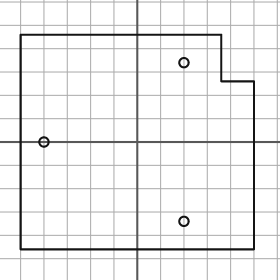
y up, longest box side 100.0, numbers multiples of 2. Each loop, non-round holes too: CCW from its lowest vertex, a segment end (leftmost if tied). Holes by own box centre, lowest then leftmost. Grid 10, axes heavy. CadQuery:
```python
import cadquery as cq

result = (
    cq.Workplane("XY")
    .moveTo(-50.0, -46.0)
    .lineTo(50.0, -46.0)
    .lineTo(50.0, 26.0)
    .lineTo(36.0, 26.0)
    .lineTo(36.0, 46.0)
    .lineTo(-50.0, 46.0)
    .close()
    .moveTo(20.0, -34.0)
    .circle(2.0)
    .moveTo(-40.0, 0.0)
    .circle(2.0)
    .moveTo(20.0, 34.0)
    .circle(2.0)
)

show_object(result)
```